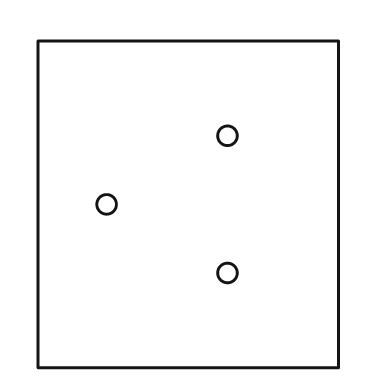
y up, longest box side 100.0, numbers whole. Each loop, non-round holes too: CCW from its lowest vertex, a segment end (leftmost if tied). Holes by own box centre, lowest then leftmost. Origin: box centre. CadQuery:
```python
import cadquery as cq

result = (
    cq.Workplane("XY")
    .moveTo(-46.0, -50.0)
    .lineTo(46.0, -50.0)
    .lineTo(46.0, 50.0)
    .lineTo(-46.0, 50.0)
    .close()
    .moveTo(12.0, -21.0)
    .circle(3.0)
    .moveTo(-25.0, 0.0)
    .circle(3.0)
    .moveTo(12.0, 21.0)
    .circle(3.0)
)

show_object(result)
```